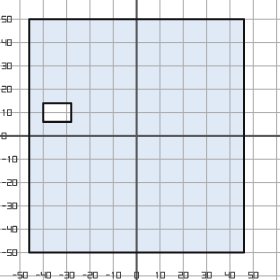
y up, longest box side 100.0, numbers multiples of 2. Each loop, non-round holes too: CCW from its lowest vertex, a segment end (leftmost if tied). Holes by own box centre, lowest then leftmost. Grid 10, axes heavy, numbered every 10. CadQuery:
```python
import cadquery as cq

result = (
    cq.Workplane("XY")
    .moveTo(-46.0, -50.0)
    .lineTo(46.0, -50.0)
    .lineTo(46.0, 50.0)
    .lineTo(-46.0, 50.0)
    .close()
    .moveTo(-40.0, 6.0)
    .lineTo(-28.0, 6.0)
    .lineTo(-28.0, 14.0)
    .lineTo(-40.0, 14.0)
    .close()
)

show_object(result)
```